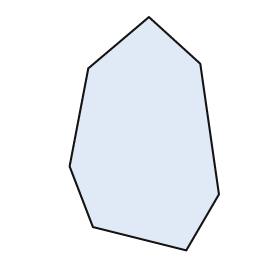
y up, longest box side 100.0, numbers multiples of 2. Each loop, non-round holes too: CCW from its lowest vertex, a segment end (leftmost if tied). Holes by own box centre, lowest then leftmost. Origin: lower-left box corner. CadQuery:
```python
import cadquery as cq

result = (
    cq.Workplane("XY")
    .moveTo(50.0, 0.0)
    .lineTo(64.0, 24.0)
    .lineTo(56.0, 80.0)
    .lineTo(34.0, 100.0)
    .lineTo(8.0, 78.0)
    .lineTo(0.0, 36.0)
    .lineTo(10.0, 10.0)
    .close()
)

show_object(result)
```